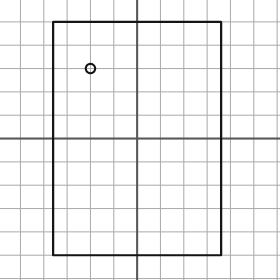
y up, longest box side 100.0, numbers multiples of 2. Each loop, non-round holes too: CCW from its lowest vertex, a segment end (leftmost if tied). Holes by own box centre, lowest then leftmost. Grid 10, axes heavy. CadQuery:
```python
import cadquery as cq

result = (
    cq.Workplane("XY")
    .moveTo(-36.0, -50.0)
    .lineTo(36.0, -50.0)
    .lineTo(36.0, 50.0)
    .lineTo(-36.0, 50.0)
    .close()
    .moveTo(-20.0, 30.0)
    .circle(2.0)
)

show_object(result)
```